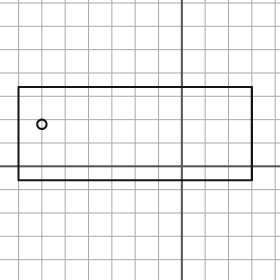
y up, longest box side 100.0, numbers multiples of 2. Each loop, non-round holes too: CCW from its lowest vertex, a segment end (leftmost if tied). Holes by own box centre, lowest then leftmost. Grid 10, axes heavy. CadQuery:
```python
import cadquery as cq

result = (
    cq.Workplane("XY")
    .moveTo(-70.0, -6.0)
    .lineTo(30.0, -6.0)
    .lineTo(30.0, 34.0)
    .lineTo(-70.0, 34.0)
    .close()
    .moveTo(-60.0, 18.0)
    .circle(2.0)
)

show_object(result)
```